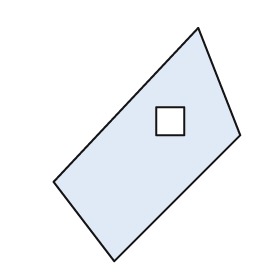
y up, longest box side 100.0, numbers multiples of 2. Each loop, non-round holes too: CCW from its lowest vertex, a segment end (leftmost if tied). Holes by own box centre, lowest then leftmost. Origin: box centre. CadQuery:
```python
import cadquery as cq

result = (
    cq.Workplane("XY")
    .moveTo(-14.0, -50.0)
    .lineTo(40.0, 4.0)
    .lineTo(22.0, 50.0)
    .lineTo(-40.0, -16.0)
    .close()
    .moveTo(4.0, 4.0)
    .lineTo(16.0, 4.0)
    .lineTo(16.0, 16.0)
    .lineTo(4.0, 16.0)
    .close()
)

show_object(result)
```